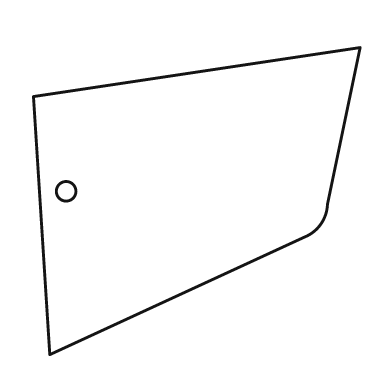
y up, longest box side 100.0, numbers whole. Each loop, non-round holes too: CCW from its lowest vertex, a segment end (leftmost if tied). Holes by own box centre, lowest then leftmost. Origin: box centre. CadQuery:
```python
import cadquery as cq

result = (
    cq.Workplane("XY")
    .moveTo(-45.0, -47.0)
    .lineTo(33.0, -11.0)
    .threePointArc((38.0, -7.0), (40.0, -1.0))
    .lineTo(50.0, 47.0)
    .lineTo(-50.0, 32.0)
    .close()
    .moveTo(-40.0, 3.0)
    .circle(3.0)
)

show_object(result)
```